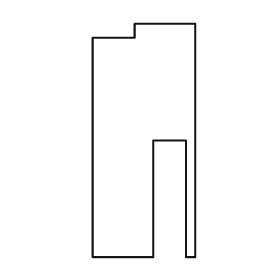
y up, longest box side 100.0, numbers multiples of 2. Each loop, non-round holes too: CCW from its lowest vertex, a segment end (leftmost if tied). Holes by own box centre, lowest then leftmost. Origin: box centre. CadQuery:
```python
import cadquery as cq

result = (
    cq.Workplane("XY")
    .moveTo(-22.0, -50.0)
    .lineTo(4.0, -50.0)
    .lineTo(4.0, 0.0)
    .lineTo(18.0, 0.0)
    .lineTo(18.0, -50.0)
    .lineTo(22.0, -50.0)
    .lineTo(22.0, 50.0)
    .lineTo(-4.0, 50.0)
    .lineTo(-4.0, 44.0)
    .lineTo(-22.0, 44.0)
    .close()
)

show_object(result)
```